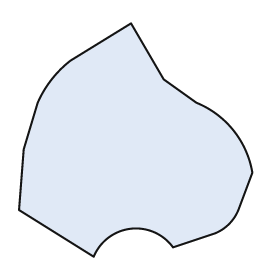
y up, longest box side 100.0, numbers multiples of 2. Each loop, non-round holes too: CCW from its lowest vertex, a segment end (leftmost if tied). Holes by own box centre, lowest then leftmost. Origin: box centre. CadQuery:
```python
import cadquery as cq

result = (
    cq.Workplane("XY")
    .moveTo(-18.0, -50.0)
    .threePointArc((-2.0, -38.0), (16.0, -46.0))
    .lineTo(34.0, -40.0)
    .threePointArc((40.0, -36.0), (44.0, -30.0))
    .lineTo(50.0, -14.0)
    .threePointArc((42.0, 4.0), (26.0, 16.0))
    .lineTo(12.0, 26.0)
    .lineTo(-2.0, 50.0)
    .lineTo(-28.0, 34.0)
    .threePointArc((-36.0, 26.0), (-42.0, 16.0))
    .lineTo(-48.0, -4.0)
    .lineTo(-50.0, -30.0)
    .close()
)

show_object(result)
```